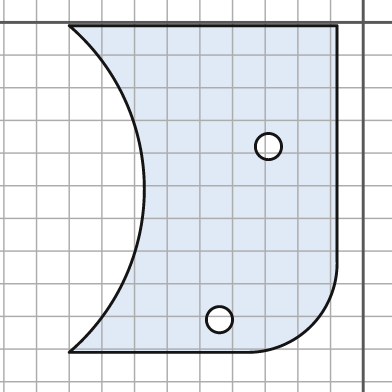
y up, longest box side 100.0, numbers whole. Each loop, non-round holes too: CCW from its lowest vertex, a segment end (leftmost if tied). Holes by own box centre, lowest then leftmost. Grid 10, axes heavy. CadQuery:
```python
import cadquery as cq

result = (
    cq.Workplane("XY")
    .moveTo(-90.0, -101.0)
    .lineTo(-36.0, -101.0)
    .threePointArc((-16.0, -93.0), (-8.0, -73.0))
    .lineTo(-8.0, -1.0)
    .lineTo(-90.0, -1.0)
    .threePointArc((-67.0, -51.0), (-90.0, -101.0))
    .close()
    .moveTo(-44.0, -91.0)
    .circle(4.0)
    .moveTo(-29.0, -38.0)
    .circle(4.0)
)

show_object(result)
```